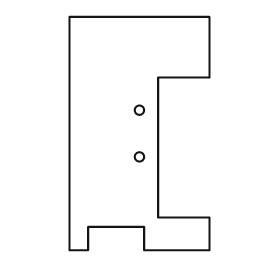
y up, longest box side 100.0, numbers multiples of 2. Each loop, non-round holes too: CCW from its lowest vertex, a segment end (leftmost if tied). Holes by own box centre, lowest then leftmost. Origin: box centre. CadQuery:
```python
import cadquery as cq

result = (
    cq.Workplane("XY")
    .moveTo(-30.0, -50.0)
    .lineTo(-22.0, -50.0)
    .lineTo(-22.0, -40.0)
    .lineTo(2.0, -40.0)
    .lineTo(2.0, -50.0)
    .lineTo(30.0, -50.0)
    .lineTo(30.0, -36.0)
    .lineTo(8.0, -36.0)
    .lineTo(8.0, 24.0)
    .lineTo(30.0, 24.0)
    .lineTo(30.0, 50.0)
    .lineTo(-30.0, 50.0)
    .close()
    .moveTo(0.0, -10.0)
    .circle(2.0)
    .moveTo(0.0, 10.0)
    .circle(2.0)
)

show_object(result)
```